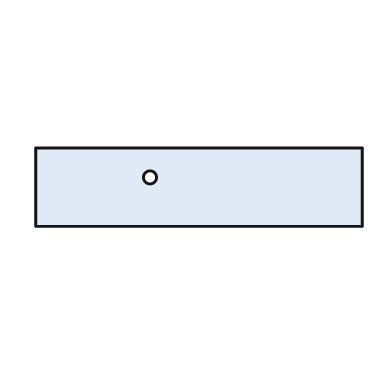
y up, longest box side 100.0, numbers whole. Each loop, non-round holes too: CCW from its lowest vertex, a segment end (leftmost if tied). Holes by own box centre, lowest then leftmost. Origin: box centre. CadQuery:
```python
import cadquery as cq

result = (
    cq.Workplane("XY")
    .moveTo(-50.0, -12.0)
    .lineTo(50.0, -12.0)
    .lineTo(50.0, 12.0)
    .lineTo(-50.0, 12.0)
    .close()
    .moveTo(-15.0, 3.0)
    .circle(2.0)
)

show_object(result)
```